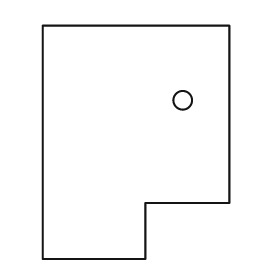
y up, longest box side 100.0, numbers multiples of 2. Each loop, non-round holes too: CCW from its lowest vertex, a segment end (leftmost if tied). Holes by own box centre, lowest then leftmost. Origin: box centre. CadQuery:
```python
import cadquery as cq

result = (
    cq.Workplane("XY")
    .moveTo(-40.0, -50.0)
    .lineTo(4.0, -50.0)
    .lineTo(4.0, -26.0)
    .lineTo(40.0, -26.0)
    .lineTo(40.0, 50.0)
    .lineTo(-40.0, 50.0)
    .close()
    .moveTo(20.0, 18.0)
    .circle(4.0)
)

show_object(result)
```